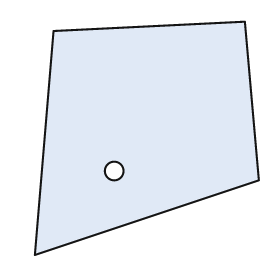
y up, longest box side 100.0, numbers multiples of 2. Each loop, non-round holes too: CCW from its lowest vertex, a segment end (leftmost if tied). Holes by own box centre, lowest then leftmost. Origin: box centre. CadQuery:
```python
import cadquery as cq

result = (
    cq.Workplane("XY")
    .moveTo(-48.0, -50.0)
    .lineTo(48.0, -18.0)
    .lineTo(42.0, 50.0)
    .lineTo(-40.0, 46.0)
    .close()
    .moveTo(-14.0, -14.0)
    .circle(4.0)
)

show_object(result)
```